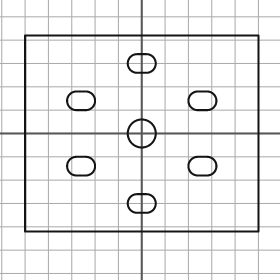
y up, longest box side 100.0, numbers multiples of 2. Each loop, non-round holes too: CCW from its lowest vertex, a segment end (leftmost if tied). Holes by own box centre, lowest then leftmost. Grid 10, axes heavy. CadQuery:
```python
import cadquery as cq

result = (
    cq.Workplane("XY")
    .moveTo(-50.0, -42.0)
    .lineTo(50.0, -42.0)
    .lineTo(50.0, 42.0)
    .lineTo(-50.0, 42.0)
    .close()
    .moveTo(-2.0, -34.0)
    .lineTo(2.0, -34.0)
    .threePointArc((6.0, -30.0), (2.0, -26.0))
    .lineTo(-2.0, -26.0)
    .threePointArc((-6.0, -30.0), (-2.0, -34.0))
    .close()
    .moveTo(-28.0, -18.0)
    .lineTo(-24.0, -18.0)
    .threePointArc((-20.0, -14.0), (-24.0, -10.0))
    .lineTo(-28.0, -10.0)
    .threePointArc((-32.0, -14.0), (-28.0, -18.0))
    .close()
    .moveTo(24.0, -18.0)
    .lineTo(28.0, -18.0)
    .threePointArc((32.0, -14.0), (28.0, -10.0))
    .lineTo(24.0, -10.0)
    .threePointArc((20.0, -14.0), (24.0, -18.0))
    .close()
    .moveTo(0.0, 0.0)
    .circle(6.0)
    .moveTo(-28.0, 10.0)
    .lineTo(-24.0, 10.0)
    .threePointArc((-20.0, 14.0), (-24.0, 18.0))
    .lineTo(-28.0, 18.0)
    .threePointArc((-32.0, 14.0), (-28.0, 10.0))
    .close()
    .moveTo(24.0, 10.0)
    .lineTo(28.0, 10.0)
    .threePointArc((32.0, 14.0), (28.0, 18.0))
    .lineTo(24.0, 18.0)
    .threePointArc((20.0, 14.0), (24.0, 10.0))
    .close()
    .moveTo(-2.0, 26.0)
    .lineTo(2.0, 26.0)
    .threePointArc((6.0, 30.0), (2.0, 34.0))
    .lineTo(-2.0, 34.0)
    .threePointArc((-6.0, 30.0), (-2.0, 26.0))
    .close()
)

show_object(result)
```